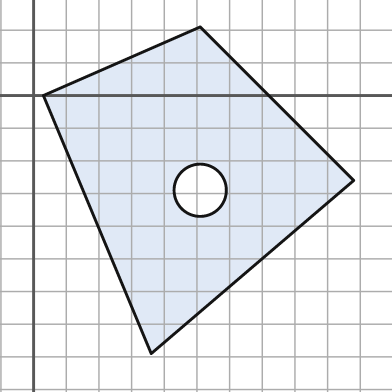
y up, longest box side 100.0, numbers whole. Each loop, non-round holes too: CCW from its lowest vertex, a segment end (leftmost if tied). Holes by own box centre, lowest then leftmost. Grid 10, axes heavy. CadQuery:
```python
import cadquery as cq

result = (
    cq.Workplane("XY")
    .moveTo(36.0, -79.0)
    .lineTo(98.0, -26.0)
    .lineTo(51.0, 21.0)
    .lineTo(3.0, 0.0)
    .close()
    .moveTo(51.0, -29.0)
    .circle(8.0)
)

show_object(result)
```